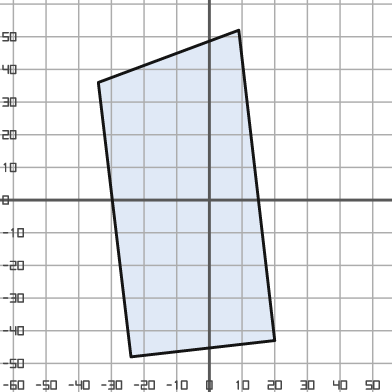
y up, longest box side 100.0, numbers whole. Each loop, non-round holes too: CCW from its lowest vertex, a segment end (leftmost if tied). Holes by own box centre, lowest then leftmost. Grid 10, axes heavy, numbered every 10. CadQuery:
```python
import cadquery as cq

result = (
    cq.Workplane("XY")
    .moveTo(-24.0, -48.0)
    .lineTo(20.0, -43.0)
    .lineTo(9.0, 52.0)
    .lineTo(-34.0, 36.0)
    .close()
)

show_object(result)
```